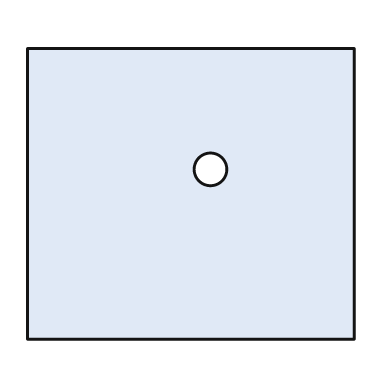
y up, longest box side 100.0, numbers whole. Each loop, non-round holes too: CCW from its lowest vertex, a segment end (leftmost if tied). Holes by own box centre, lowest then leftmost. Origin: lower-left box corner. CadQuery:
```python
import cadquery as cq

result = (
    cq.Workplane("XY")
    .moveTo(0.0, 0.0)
    .lineTo(100.0, 0.0)
    .lineTo(100.0, 89.0)
    .lineTo(0.0, 89.0)
    .close()
    .moveTo(56.0, 52.0)
    .circle(5.0)
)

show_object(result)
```